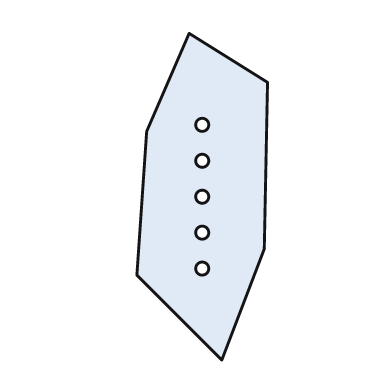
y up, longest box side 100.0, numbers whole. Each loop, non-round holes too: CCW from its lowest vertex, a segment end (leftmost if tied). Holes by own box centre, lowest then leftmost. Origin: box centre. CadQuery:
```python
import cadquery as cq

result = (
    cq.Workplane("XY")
    .moveTo(6.0, -50.0)
    .lineTo(19.0, -16.0)
    .lineTo(20.0, 35.0)
    .lineTo(-4.0, 50.0)
    .lineTo(-17.0, 20.0)
    .lineTo(-20.0, -24.0)
    .close()
    .moveTo(0.0, -22.0)
    .circle(2.0)
    .moveTo(0.0, -11.0)
    .circle(2.0)
    .moveTo(0.0, 0.0)
    .circle(2.0)
    .moveTo(0.0, 11.0)
    .circle(2.0)
    .moveTo(0.0, 22.0)
    .circle(2.0)
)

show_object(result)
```